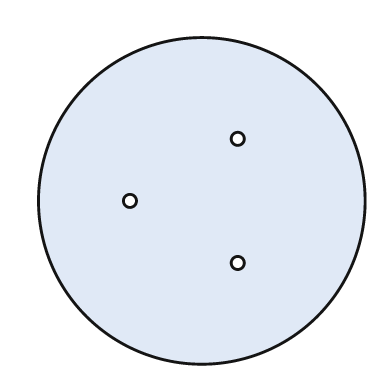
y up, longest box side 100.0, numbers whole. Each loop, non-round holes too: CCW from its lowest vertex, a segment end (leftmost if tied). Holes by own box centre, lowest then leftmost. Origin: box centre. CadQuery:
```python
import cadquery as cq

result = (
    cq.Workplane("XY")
    .moveTo(0.0, 0.0)
    .circle(50.0)
    .moveTo(11.0, -19.0)
    .circle(2.0)
    .moveTo(-22.0, 0.0)
    .circle(2.0)
    .moveTo(11.0, 19.0)
    .circle(2.0)
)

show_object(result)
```